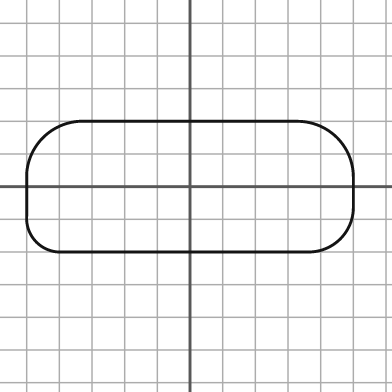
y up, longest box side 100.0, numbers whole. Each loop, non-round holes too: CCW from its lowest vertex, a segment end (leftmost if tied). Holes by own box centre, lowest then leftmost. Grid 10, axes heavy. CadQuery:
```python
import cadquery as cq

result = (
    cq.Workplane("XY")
    .moveTo(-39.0, -20.0)
    .lineTo(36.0, -20.0)
    .threePointArc((46.0, -16.0), (50.0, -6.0))
    .lineTo(50.0, 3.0)
    .threePointArc((45.0, 15.0), (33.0, 20.0))
    .lineTo(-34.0, 20.0)
    .threePointArc((-45.0, 15.0), (-50.0, 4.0))
    .lineTo(-50.0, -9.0)
    .threePointArc((-47.0, -17.0), (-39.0, -20.0))
    .close()
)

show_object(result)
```